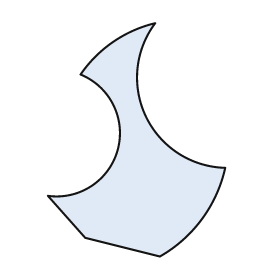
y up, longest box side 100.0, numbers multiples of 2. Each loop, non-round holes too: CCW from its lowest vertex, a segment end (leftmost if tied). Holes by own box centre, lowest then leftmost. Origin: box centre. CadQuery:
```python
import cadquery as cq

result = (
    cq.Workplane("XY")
    .moveTo(10.0, -50.0)
    .threePointArc((28.0, -34.0), (38.0, -12.0))
    .threePointArc((4.0, 10.0), (8.0, 50.0))
    .threePointArc((-10.0, 42.0), (-24.0, 28.0))
    .threePointArc((-8.0, -4.0), (-38.0, -24.0))
    .lineTo(-22.0, -42.0)
    .close()
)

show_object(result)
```